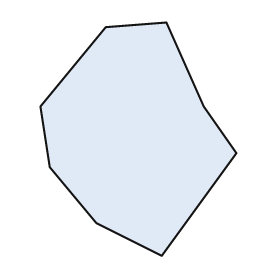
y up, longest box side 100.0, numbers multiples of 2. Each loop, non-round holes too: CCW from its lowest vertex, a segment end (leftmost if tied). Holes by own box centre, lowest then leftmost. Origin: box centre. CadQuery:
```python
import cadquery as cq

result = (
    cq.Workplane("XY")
    .moveTo(10.0, -50.0)
    .lineTo(42.0, -6.0)
    .lineTo(28.0, 14.0)
    .lineTo(12.0, 50.0)
    .lineTo(-14.0, 48.0)
    .lineTo(-42.0, 14.0)
    .lineTo(-38.0, -12.0)
    .lineTo(-18.0, -36.0)
    .close()
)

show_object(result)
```